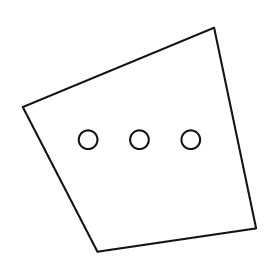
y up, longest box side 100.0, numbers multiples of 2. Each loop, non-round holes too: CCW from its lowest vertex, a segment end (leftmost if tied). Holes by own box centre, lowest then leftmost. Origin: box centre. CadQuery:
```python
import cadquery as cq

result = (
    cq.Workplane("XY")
    .moveTo(-18.0, -48.0)
    .lineTo(50.0, -38.0)
    .lineTo(32.0, 48.0)
    .lineTo(-50.0, 14.0)
    .close()
    .moveTo(-22.0, 0.0)
    .circle(4.0)
    .moveTo(0.0, 0.0)
    .circle(4.0)
    .moveTo(22.0, 0.0)
    .circle(4.0)
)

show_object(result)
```